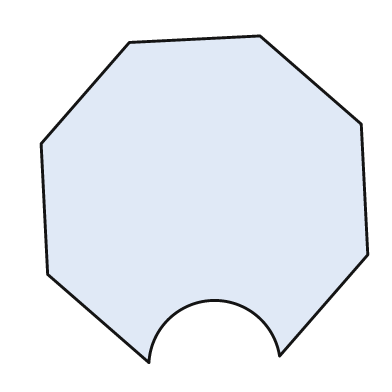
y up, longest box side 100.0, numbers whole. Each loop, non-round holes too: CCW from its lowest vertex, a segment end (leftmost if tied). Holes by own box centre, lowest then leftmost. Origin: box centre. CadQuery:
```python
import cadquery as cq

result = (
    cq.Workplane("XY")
    .moveTo(-17.0, -50.0)
    .threePointArc((2.0, -31.0), (23.0, -48.0))
    .lineTo(50.0, -17.0)
    .lineTo(48.0, 23.0)
    .lineTo(17.0, 50.0)
    .lineTo(-23.0, 48.0)
    .lineTo(-50.0, 17.0)
    .lineTo(-48.0, -23.0)
    .close()
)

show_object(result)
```